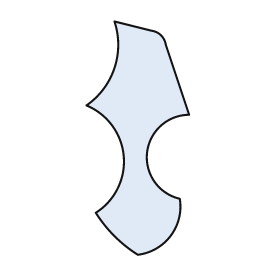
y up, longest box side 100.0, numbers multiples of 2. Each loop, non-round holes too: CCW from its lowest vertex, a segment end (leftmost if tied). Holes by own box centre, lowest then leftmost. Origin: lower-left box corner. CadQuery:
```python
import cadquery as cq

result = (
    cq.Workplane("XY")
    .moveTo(22.0, 0.0)
    .threePointArc((36.0, 8.0), (40.0, 24.0))
    .threePointArc((26.0, 44.0), (44.0, 60.0))
    .lineTo(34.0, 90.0)
    .threePointArc((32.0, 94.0), (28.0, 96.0))
    .lineTo(12.0, 100.0)
    .threePointArc((12.0, 80.0), (0.0, 64.0))
    .threePointArc((16.0, 42.0), (4.0, 18.0))
    .threePointArc((12.0, 8.0), (22.0, 0.0))
    .close()
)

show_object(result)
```